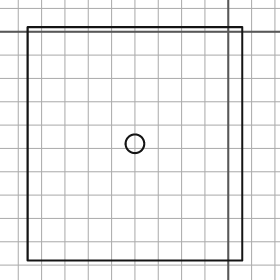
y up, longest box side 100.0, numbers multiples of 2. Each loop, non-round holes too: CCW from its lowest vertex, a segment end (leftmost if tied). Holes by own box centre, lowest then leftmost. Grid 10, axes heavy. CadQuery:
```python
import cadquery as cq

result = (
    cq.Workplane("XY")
    .moveTo(-86.0, -98.0)
    .lineTo(6.0, -98.0)
    .lineTo(6.0, 2.0)
    .lineTo(-86.0, 2.0)
    .close()
    .moveTo(-40.0, -48.0)
    .circle(4.0)
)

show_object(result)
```